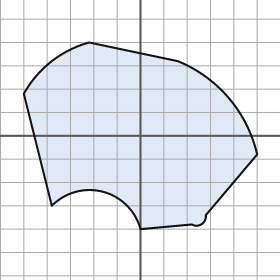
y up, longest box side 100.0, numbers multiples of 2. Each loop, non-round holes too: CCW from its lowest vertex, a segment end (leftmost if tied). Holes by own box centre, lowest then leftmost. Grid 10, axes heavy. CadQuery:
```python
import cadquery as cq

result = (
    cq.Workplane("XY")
    .moveTo(0.0, -40.0)
    .lineTo(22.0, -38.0)
    .threePointArc((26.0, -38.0), (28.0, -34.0))
    .lineTo(50.0, -8.0)
    .threePointArc((38.0, 16.0), (16.0, 32.0))
    .lineTo(-22.0, 40.0)
    .threePointArc((-38.0, 32.0), (-50.0, 18.0))
    .lineTo(-38.0, -30.0)
    .threePointArc((-16.0, -24.0), (0.0, -40.0))
    .close()
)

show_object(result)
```